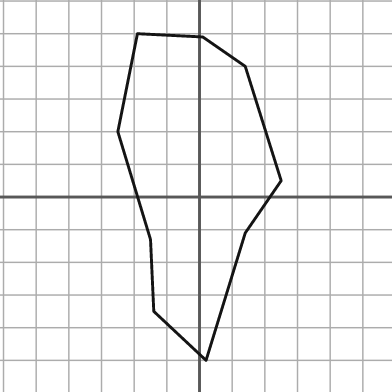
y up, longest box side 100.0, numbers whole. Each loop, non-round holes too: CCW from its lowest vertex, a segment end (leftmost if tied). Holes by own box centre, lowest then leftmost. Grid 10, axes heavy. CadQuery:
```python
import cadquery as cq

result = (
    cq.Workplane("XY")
    .moveTo(2.0, -50.0)
    .lineTo(14.0, -11.0)
    .lineTo(25.0, 5.0)
    .lineTo(14.0, 40.0)
    .lineTo(1.0, 49.0)
    .lineTo(-19.0, 50.0)
    .lineTo(-25.0, 20.0)
    .lineTo(-15.0, -13.0)
    .lineTo(-14.0, -35.0)
    .close()
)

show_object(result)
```